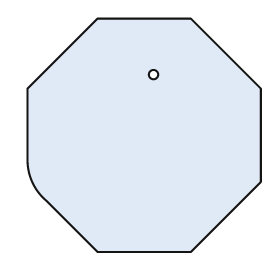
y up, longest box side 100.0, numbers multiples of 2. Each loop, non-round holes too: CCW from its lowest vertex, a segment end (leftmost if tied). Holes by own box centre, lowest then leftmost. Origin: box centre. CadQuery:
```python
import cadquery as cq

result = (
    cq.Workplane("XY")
    .moveTo(-20.0, -50.0)
    .lineTo(20.0, -50.0)
    .lineTo(50.0, -20.0)
    .lineTo(50.0, 20.0)
    .lineTo(20.0, 50.0)
    .lineTo(-20.0, 50.0)
    .lineTo(-50.0, 20.0)
    .lineTo(-50.0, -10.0)
    .threePointArc((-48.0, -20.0), (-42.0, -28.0))
    .close()
    .moveTo(4.0, 26.0)
    .circle(2.0)
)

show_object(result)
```